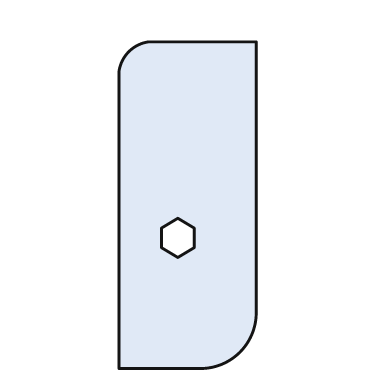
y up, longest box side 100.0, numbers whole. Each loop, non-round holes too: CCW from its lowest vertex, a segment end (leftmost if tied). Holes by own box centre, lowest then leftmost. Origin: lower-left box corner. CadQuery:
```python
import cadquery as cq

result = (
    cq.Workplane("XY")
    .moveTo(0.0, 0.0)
    .lineTo(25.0, 0.0)
    .threePointArc((37.0, 5.0), (42.0, 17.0))
    .lineTo(42.0, 100.0)
    .lineTo(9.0, 100.0)
    .threePointArc((3.0, 97.0), (0.0, 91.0))
    .close()
    .moveTo(18.0, 34.0)
    .lineTo(23.0, 37.0)
    .lineTo(23.0, 43.0)
    .lineTo(18.0, 46.0)
    .lineTo(13.0, 43.0)
    .lineTo(13.0, 37.0)
    .close()
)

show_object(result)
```